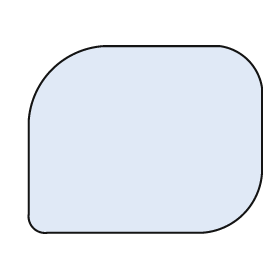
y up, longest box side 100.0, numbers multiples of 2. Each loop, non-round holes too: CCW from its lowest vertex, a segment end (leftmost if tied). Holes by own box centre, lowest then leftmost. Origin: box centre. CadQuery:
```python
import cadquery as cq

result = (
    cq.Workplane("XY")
    .moveTo(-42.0, -40.0)
    .lineTo(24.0, -40.0)
    .threePointArc((42.0, -32.0), (50.0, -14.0))
    .lineTo(50.0, 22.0)
    .threePointArc((44.0, 34.0), (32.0, 40.0))
    .lineTo(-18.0, 40.0)
    .threePointArc((-40.0, 30.0), (-50.0, 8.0))
    .lineTo(-50.0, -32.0)
    .threePointArc((-48.0, -38.0), (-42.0, -40.0))
    .close()
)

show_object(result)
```